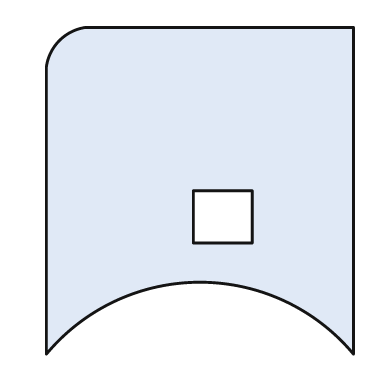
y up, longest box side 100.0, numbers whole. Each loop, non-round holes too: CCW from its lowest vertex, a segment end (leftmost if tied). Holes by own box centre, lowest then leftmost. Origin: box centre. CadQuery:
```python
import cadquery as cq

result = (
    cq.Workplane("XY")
    .moveTo(-47.0, -50.0)
    .threePointArc((0.0, -28.0), (47.0, -50.0))
    .lineTo(47.0, 50.0)
    .lineTo(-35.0, 50.0)
    .threePointArc((-43.0, 46.0), (-47.0, 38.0))
    .close()
    .moveTo(-2.0, -16.0)
    .lineTo(16.0, -16.0)
    .lineTo(16.0, 0.0)
    .lineTo(-2.0, 0.0)
    .close()
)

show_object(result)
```